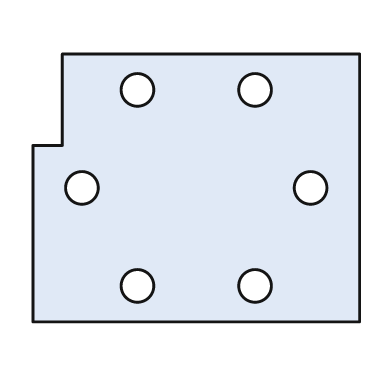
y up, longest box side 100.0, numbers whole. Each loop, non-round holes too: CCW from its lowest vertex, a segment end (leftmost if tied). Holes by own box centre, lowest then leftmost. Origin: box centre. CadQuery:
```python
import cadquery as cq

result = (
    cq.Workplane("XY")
    .moveTo(-50.0, -41.0)
    .lineTo(50.0, -41.0)
    .lineTo(50.0, 41.0)
    .lineTo(-41.0, 41.0)
    .lineTo(-41.0, 13.0)
    .lineTo(-50.0, 13.0)
    .close()
    .moveTo(-18.0, -30.0)
    .circle(5.0)
    .moveTo(18.0, -30.0)
    .circle(5.0)
    .moveTo(-35.0, 0.0)
    .circle(5.0)
    .moveTo(35.0, 0.0)
    .circle(5.0)
    .moveTo(-18.0, 30.0)
    .circle(5.0)
    .moveTo(18.0, 30.0)
    .circle(5.0)
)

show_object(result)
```